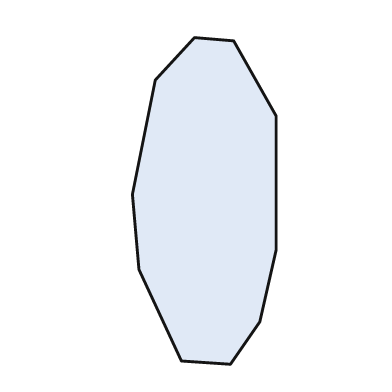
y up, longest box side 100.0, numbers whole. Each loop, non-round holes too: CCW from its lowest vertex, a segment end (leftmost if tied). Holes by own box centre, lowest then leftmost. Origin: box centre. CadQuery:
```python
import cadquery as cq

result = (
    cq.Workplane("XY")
    .moveTo(8.0, -50.0)
    .lineTo(17.0, -37.0)
    .lineTo(22.0, -15.0)
    .lineTo(22.0, 26.0)
    .lineTo(9.0, 49.0)
    .lineTo(-3.0, 50.0)
    .lineTo(-15.0, 37.0)
    .lineTo(-22.0, 2.0)
    .lineTo(-20.0, -21.0)
    .lineTo(-7.0, -49.0)
    .close()
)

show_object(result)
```